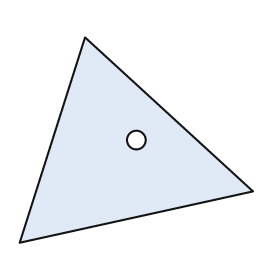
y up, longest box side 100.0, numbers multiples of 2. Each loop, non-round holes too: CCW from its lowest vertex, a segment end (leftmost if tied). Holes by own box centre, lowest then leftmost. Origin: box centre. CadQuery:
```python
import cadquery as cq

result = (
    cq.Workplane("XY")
    .moveTo(-50.0, -44.0)
    .lineTo(50.0, -22.0)
    .lineTo(-22.0, 44.0)
    .close()
    .moveTo(0.0, 0.0)
    .circle(4.0)
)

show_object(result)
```